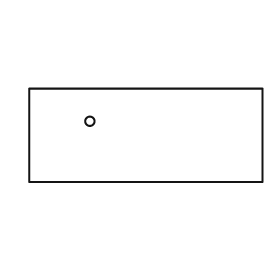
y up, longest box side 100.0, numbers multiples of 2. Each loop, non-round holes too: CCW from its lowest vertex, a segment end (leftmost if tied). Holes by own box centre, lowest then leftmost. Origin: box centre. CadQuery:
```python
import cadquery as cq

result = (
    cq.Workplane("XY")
    .moveTo(-50.0, -20.0)
    .lineTo(50.0, -20.0)
    .lineTo(50.0, 20.0)
    .lineTo(-50.0, 20.0)
    .close()
    .moveTo(-24.0, 6.0)
    .circle(2.0)
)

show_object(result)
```